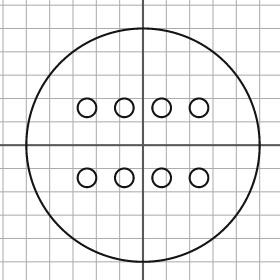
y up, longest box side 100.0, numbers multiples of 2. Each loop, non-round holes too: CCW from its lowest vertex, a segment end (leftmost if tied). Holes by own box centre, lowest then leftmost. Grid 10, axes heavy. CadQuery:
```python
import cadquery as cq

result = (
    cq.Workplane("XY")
    .moveTo(0.0, 0.0)
    .circle(50.0)
    .moveTo(-24.0, -14.0)
    .circle(4.0)
    .moveTo(-8.0, -14.0)
    .circle(4.0)
    .moveTo(8.0, -14.0)
    .circle(4.0)
    .moveTo(24.0, -14.0)
    .circle(4.0)
    .moveTo(-24.0, 16.0)
    .circle(4.0)
    .moveTo(-8.0, 16.0)
    .circle(4.0)
    .moveTo(8.0, 16.0)
    .circle(4.0)
    .moveTo(24.0, 16.0)
    .circle(4.0)
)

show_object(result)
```